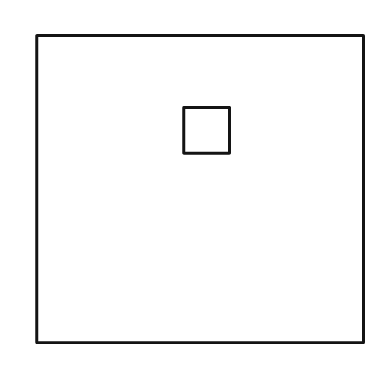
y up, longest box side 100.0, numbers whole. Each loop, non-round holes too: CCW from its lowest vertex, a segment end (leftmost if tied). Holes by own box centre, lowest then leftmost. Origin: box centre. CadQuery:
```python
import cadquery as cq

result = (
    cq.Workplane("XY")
    .moveTo(-50.0, -47.0)
    .lineTo(50.0, -47.0)
    .lineTo(50.0, 47.0)
    .lineTo(-50.0, 47.0)
    .close()
    .moveTo(-5.0, 11.0)
    .lineTo(9.0, 11.0)
    .lineTo(9.0, 25.0)
    .lineTo(-5.0, 25.0)
    .close()
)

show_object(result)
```